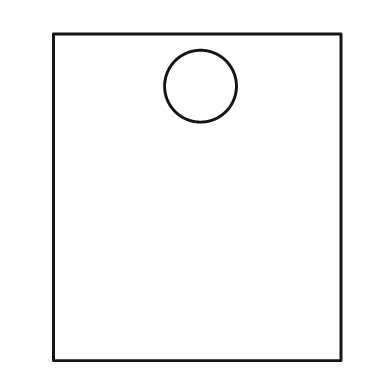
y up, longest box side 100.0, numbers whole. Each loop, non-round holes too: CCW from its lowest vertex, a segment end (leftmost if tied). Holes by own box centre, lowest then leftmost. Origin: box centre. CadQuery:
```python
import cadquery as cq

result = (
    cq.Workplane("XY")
    .moveTo(-44.0, -50.0)
    .lineTo(44.0, -50.0)
    .lineTo(44.0, 50.0)
    .lineTo(-44.0, 50.0)
    .close()
    .moveTo(1.0, 34.0)
    .circle(11.0)
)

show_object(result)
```